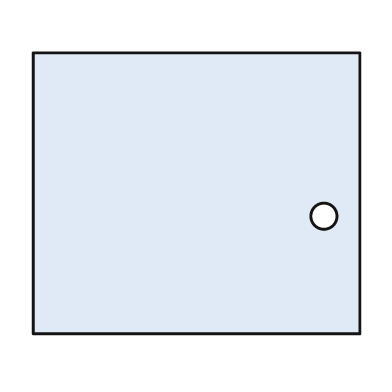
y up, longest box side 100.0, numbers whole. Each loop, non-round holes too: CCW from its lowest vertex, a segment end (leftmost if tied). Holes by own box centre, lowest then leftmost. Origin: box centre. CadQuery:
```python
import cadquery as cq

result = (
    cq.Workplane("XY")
    .moveTo(-50.0, -43.0)
    .lineTo(50.0, -43.0)
    .lineTo(50.0, 43.0)
    .lineTo(-50.0, 43.0)
    .close()
    .moveTo(39.0, -7.0)
    .circle(4.0)
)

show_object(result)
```